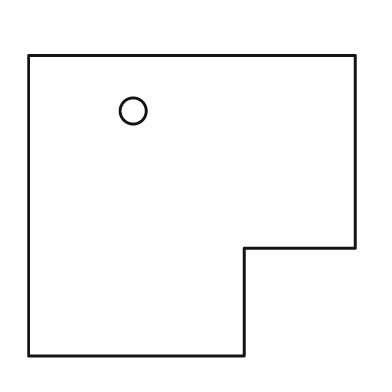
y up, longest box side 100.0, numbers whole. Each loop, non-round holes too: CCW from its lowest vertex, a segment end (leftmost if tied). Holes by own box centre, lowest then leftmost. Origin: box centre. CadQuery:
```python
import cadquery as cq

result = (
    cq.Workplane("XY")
    .moveTo(-50.0, -46.0)
    .lineTo(16.0, -46.0)
    .lineTo(16.0, -13.0)
    .lineTo(50.0, -13.0)
    .lineTo(50.0, 46.0)
    .lineTo(-50.0, 46.0)
    .close()
    .moveTo(-18.0, 29.0)
    .circle(4.0)
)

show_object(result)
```